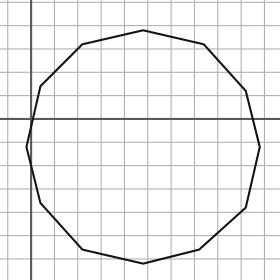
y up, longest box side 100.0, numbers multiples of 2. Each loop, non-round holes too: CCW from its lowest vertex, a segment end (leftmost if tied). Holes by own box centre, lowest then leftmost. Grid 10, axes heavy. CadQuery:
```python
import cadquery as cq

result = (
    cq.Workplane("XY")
    .moveTo(48.0, -62.0)
    .lineTo(72.0, -56.0)
    .lineTo(92.0, -38.0)
    .lineTo(98.0, -12.0)
    .lineTo(92.0, 12.0)
    .lineTo(74.0, 32.0)
    .lineTo(48.0, 38.0)
    .lineTo(22.0, 32.0)
    .lineTo(4.0, 14.0)
    .lineTo(-2.0, -12.0)
    .lineTo(4.0, -36.0)
    .lineTo(22.0, -56.0)
    .close()
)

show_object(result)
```